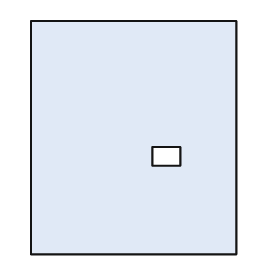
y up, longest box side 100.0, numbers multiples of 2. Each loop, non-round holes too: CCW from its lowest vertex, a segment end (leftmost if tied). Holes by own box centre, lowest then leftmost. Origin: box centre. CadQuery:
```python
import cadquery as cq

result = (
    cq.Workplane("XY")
    .moveTo(-44.0, -50.0)
    .lineTo(44.0, -50.0)
    .lineTo(44.0, 50.0)
    .lineTo(-44.0, 50.0)
    .close()
    .moveTo(8.0, -12.0)
    .lineTo(20.0, -12.0)
    .lineTo(20.0, -4.0)
    .lineTo(8.0, -4.0)
    .close()
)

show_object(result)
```